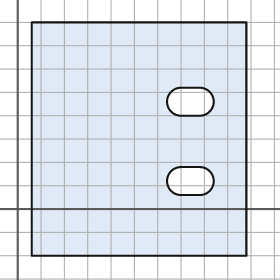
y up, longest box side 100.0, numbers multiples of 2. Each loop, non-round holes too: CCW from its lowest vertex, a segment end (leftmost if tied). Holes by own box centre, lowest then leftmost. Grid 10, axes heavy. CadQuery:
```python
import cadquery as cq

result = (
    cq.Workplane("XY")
    .moveTo(6.0, -20.0)
    .lineTo(98.0, -20.0)
    .lineTo(98.0, 80.0)
    .lineTo(6.0, 80.0)
    .close()
    .moveTo(70.0, 6.0)
    .lineTo(78.0, 6.0)
    .threePointArc((84.0, 12.0), (78.0, 18.0))
    .lineTo(70.0, 18.0)
    .threePointArc((64.0, 12.0), (70.0, 6.0))
    .close()
    .moveTo(70.0, 40.0)
    .lineTo(78.0, 40.0)
    .threePointArc((84.0, 46.0), (78.0, 52.0))
    .lineTo(70.0, 52.0)
    .threePointArc((64.0, 46.0), (70.0, 40.0))
    .close()
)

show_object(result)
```